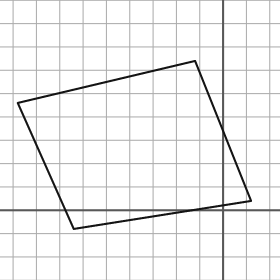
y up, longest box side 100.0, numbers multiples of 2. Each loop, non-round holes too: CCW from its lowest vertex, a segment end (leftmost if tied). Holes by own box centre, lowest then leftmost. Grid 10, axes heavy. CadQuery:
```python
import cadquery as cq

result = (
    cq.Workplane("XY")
    .moveTo(-64.0, -8.0)
    .lineTo(12.0, 4.0)
    .lineTo(-12.0, 64.0)
    .lineTo(-88.0, 46.0)
    .close()
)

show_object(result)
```